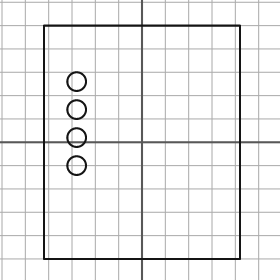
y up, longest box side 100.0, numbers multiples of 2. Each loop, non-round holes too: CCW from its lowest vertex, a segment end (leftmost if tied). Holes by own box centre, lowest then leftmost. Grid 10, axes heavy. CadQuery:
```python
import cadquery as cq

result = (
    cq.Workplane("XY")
    .moveTo(-42.0, -50.0)
    .lineTo(42.0, -50.0)
    .lineTo(42.0, 50.0)
    .lineTo(-42.0, 50.0)
    .close()
    .moveTo(-28.0, -10.0)
    .circle(4.0)
    .moveTo(-28.0, 2.0)
    .circle(4.0)
    .moveTo(-28.0, 14.0)
    .circle(4.0)
    .moveTo(-28.0, 26.0)
    .circle(4.0)
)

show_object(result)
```